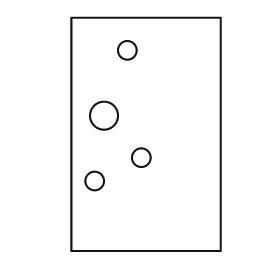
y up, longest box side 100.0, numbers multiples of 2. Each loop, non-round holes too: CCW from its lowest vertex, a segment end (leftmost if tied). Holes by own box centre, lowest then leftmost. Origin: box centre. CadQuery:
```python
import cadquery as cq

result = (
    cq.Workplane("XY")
    .moveTo(-32.0, -50.0)
    .lineTo(32.0, -50.0)
    .lineTo(32.0, 50.0)
    .lineTo(-32.0, 50.0)
    .close()
    .moveTo(-22.0, -20.0)
    .circle(4.0)
    .moveTo(-2.0, -10.0)
    .circle(4.0)
    .moveTo(-18.0, 8.0)
    .circle(6.0)
    .moveTo(-8.0, 36.0)
    .circle(4.0)
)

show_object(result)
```